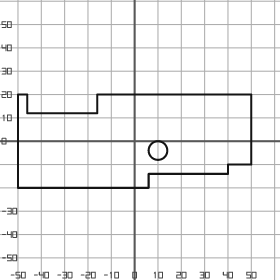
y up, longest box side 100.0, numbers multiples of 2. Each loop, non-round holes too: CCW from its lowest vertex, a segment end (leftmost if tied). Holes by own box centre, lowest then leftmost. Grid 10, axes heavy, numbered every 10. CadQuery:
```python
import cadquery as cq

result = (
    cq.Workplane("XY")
    .moveTo(-50.0, -20.0)
    .lineTo(6.0, -20.0)
    .lineTo(6.0, -14.0)
    .lineTo(40.0, -14.0)
    .lineTo(40.0, -10.0)
    .lineTo(50.0, -10.0)
    .lineTo(50.0, 20.0)
    .lineTo(-16.0, 20.0)
    .lineTo(-16.0, 12.0)
    .lineTo(-46.0, 12.0)
    .lineTo(-46.0, 20.0)
    .lineTo(-50.0, 20.0)
    .close()
    .moveTo(10.0, -4.0)
    .circle(4.0)
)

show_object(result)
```